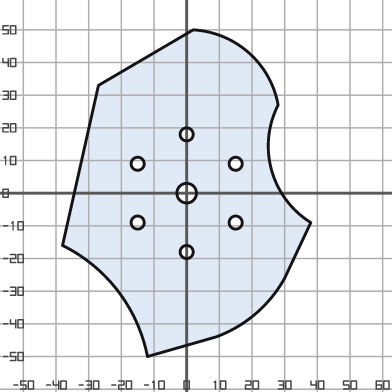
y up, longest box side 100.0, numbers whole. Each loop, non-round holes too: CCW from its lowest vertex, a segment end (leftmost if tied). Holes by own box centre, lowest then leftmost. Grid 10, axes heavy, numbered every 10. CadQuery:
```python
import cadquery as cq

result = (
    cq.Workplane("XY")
    .moveTo(-12.0, -50.0)
    .lineTo(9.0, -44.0)
    .threePointArc((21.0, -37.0), (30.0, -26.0))
    .lineTo(38.0, -9.0)
    .threePointArc((26.0, 7.0), (28.0, 27.0))
    .threePointArc((19.0, 43.0), (2.0, 50.0))
    .lineTo(-27.0, 33.0)
    .lineTo(-38.0, -16.0)
    .threePointArc((-21.0, -30.0), (-12.0, -50.0))
    .close()
    .moveTo(0.0, -18.0)
    .circle(2.0)
    .moveTo(-15.0, -9.0)
    .circle(2.0)
    .moveTo(15.0, -9.0)
    .circle(2.0)
    .moveTo(0.0, 0.0)
    .circle(3.0)
    .moveTo(-15.0, 9.0)
    .circle(2.0)
    .moveTo(15.0, 9.0)
    .circle(2.0)
    .moveTo(0.0, 18.0)
    .circle(2.0)
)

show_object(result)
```